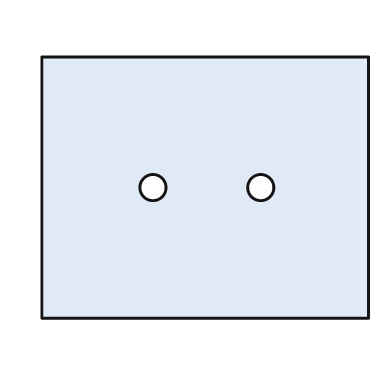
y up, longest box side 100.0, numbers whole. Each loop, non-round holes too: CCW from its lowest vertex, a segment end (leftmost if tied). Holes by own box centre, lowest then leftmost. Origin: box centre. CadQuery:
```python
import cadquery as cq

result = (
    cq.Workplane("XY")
    .moveTo(-50.0, -40.0)
    .lineTo(50.0, -40.0)
    .lineTo(50.0, 40.0)
    .lineTo(-50.0, 40.0)
    .close()
    .moveTo(-16.0, 0.0)
    .circle(4.0)
    .moveTo(17.0, 0.0)
    .circle(4.0)
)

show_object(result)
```